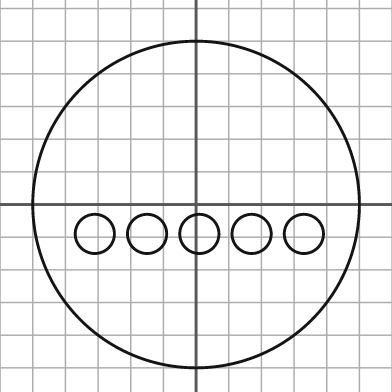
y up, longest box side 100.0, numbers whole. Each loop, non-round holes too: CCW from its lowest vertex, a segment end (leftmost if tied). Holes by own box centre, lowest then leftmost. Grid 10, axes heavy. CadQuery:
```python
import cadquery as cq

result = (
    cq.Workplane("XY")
    .moveTo(0.0, 0.0)
    .circle(50.0)
    .moveTo(-31.0, -9.0)
    .circle(6.0)
    .moveTo(-15.0, -9.0)
    .circle(6.0)
    .moveTo(1.0, -9.0)
    .circle(6.0)
    .moveTo(17.0, -9.0)
    .circle(6.0)
    .moveTo(33.0, -9.0)
    .circle(6.0)
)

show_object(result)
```